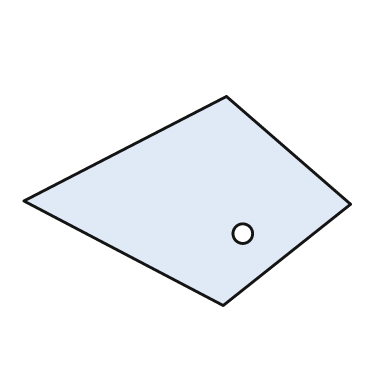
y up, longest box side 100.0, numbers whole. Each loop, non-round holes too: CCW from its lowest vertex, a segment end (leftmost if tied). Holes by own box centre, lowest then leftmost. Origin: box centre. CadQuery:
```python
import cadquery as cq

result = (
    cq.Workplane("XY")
    .moveTo(11.0, -32.0)
    .lineTo(50.0, -1.0)
    .lineTo(12.0, 32.0)
    .lineTo(-50.0, 0.0)
    .close()
    .moveTo(17.0, -10.0)
    .circle(3.0)
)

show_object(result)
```